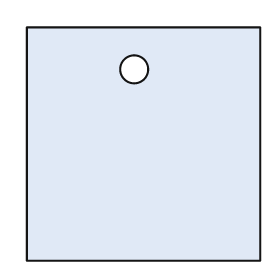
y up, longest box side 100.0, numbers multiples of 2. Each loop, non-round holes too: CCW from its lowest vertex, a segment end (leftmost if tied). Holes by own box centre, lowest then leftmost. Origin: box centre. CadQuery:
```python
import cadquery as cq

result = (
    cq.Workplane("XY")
    .moveTo(-50.0, -50.0)
    .lineTo(50.0, -50.0)
    .lineTo(50.0, 50.0)
    .lineTo(-50.0, 50.0)
    .close()
    .moveTo(-4.0, 32.0)
    .circle(6.0)
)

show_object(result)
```